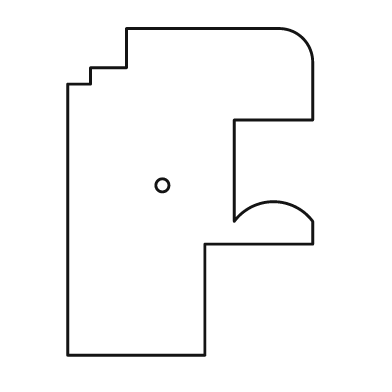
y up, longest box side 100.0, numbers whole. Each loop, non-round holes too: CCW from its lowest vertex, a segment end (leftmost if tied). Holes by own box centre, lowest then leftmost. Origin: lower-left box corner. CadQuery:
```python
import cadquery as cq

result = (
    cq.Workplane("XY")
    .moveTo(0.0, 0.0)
    .lineTo(42.0, 0.0)
    .lineTo(42.0, 34.0)
    .lineTo(75.0, 34.0)
    .lineTo(75.0, 41.0)
    .threePointArc((63.0, 47.0), (51.0, 41.0))
    .lineTo(51.0, 72.0)
    .lineTo(75.0, 72.0)
    .lineTo(75.0, 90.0)
    .threePointArc((72.0, 97.0), (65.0, 100.0))
    .lineTo(18.0, 100.0)
    .lineTo(18.0, 88.0)
    .lineTo(7.0, 88.0)
    .lineTo(7.0, 83.0)
    .lineTo(0.0, 83.0)
    .close()
    .moveTo(29.0, 52.0)
    .circle(2.0)
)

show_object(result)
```